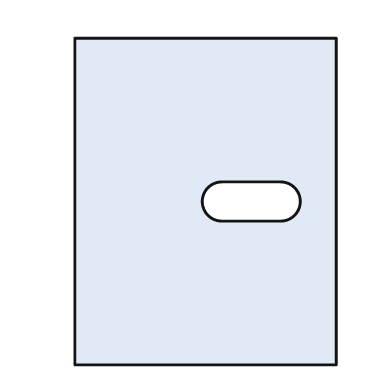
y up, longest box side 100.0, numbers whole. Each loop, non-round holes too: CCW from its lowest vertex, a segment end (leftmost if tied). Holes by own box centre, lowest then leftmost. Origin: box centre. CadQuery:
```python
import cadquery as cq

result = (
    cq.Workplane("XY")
    .moveTo(-40.0, -50.0)
    .lineTo(40.0, -50.0)
    .lineTo(40.0, 50.0)
    .lineTo(-40.0, 50.0)
    .close()
    .moveTo(5.0, -6.0)
    .lineTo(23.0, -6.0)
    .threePointArc((29.0, 0.0), (23.0, 6.0))
    .lineTo(5.0, 6.0)
    .threePointArc((-1.0, 0.0), (5.0, -6.0))
    .close()
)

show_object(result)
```